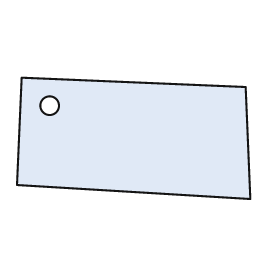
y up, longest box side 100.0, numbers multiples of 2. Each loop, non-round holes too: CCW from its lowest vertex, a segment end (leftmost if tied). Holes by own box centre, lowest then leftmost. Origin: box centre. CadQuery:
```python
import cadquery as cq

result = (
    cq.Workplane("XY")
    .moveTo(50.0, -26.0)
    .lineTo(48.0, 22.0)
    .lineTo(-48.0, 26.0)
    .lineTo(-50.0, -20.0)
    .close()
    .moveTo(-36.0, 14.0)
    .circle(4.0)
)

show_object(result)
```